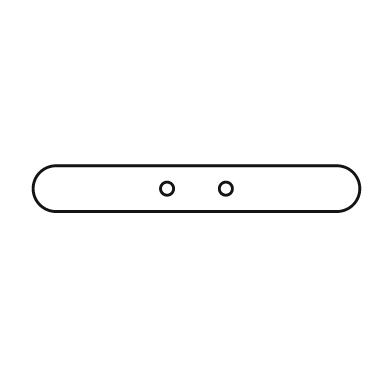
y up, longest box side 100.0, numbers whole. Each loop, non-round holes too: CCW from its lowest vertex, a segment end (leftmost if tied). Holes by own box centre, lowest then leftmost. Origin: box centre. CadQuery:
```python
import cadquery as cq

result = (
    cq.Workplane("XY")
    .moveTo(-43.0, -7.0)
    .lineTo(43.0, -7.0)
    .threePointArc((50.0, 0.0), (43.0, 7.0))
    .lineTo(-43.0, 7.0)
    .threePointArc((-50.0, 0.0), (-43.0, -7.0))
    .close()
    .moveTo(-9.0, 0.0)
    .circle(2.0)
    .moveTo(9.0, 0.0)
    .circle(2.0)
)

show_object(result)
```